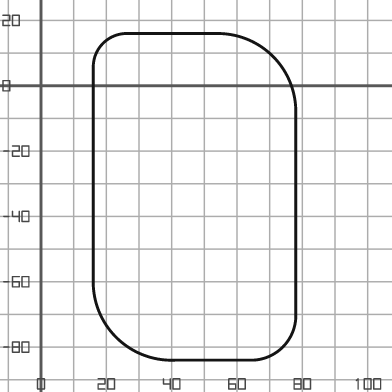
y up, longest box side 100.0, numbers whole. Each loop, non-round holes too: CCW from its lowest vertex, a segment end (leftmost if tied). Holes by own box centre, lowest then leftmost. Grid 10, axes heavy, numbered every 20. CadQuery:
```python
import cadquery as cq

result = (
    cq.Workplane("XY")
    .moveTo(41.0, -84.0)
    .lineTo(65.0, -84.0)
    .threePointArc((74.0, -80.0), (78.0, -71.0))
    .lineTo(78.0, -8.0)
    .threePointArc((71.0, 9.0), (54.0, 16.0))
    .lineTo(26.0, 16.0)
    .threePointArc((19.0, 13.0), (16.0, 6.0))
    .lineTo(16.0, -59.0)
    .threePointArc((23.0, -77.0), (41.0, -84.0))
    .close()
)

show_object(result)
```